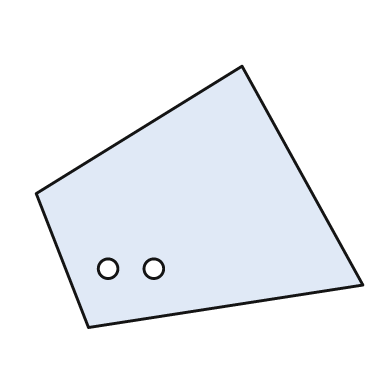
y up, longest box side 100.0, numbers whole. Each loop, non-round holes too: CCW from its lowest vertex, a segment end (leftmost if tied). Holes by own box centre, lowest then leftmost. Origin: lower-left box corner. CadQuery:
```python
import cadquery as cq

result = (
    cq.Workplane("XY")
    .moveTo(16.0, 0.0)
    .lineTo(100.0, 13.0)
    .lineTo(63.0, 80.0)
    .lineTo(0.0, 41.0)
    .close()
    .moveTo(22.0, 18.0)
    .circle(3.0)
    .moveTo(36.0, 18.0)
    .circle(3.0)
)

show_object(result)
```